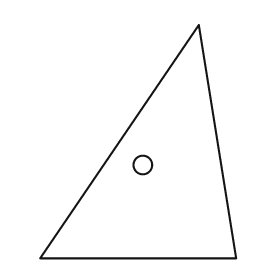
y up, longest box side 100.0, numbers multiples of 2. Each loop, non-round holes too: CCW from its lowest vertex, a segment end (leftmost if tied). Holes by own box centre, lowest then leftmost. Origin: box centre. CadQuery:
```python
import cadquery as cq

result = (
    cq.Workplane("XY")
    .moveTo(-42.0, -50.0)
    .lineTo(42.0, -50.0)
    .lineTo(26.0, 50.0)
    .close()
    .moveTo(2.0, -10.0)
    .circle(4.0)
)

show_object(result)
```